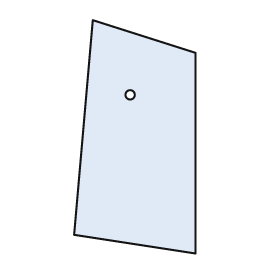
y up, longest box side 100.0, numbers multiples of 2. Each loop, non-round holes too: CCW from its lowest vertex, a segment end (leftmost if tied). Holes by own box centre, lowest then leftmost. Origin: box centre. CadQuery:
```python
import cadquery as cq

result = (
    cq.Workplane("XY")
    .moveTo(26.0, -50.0)
    .lineTo(26.0, 36.0)
    .lineTo(-18.0, 50.0)
    .lineTo(-26.0, -42.0)
    .close()
    .moveTo(-2.0, 18.0)
    .circle(2.0)
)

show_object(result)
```